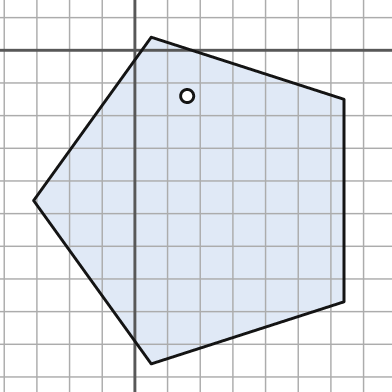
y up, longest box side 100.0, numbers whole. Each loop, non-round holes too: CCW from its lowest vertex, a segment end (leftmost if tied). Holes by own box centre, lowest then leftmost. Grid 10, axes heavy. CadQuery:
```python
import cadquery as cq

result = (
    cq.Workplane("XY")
    .moveTo(5.0, -96.0)
    .lineTo(64.0, -77.0)
    .lineTo(64.0, -15.0)
    .lineTo(5.0, 4.0)
    .lineTo(-31.0, -46.0)
    .close()
    .moveTo(16.0, -14.0)
    .circle(2.0)
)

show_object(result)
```